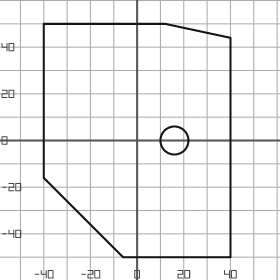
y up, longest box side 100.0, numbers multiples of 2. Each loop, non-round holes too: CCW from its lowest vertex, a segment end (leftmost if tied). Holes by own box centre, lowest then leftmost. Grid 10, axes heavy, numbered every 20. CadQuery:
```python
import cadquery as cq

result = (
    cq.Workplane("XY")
    .moveTo(-6.0, -50.0)
    .lineTo(40.0, -50.0)
    .lineTo(40.0, 44.0)
    .lineTo(12.0, 50.0)
    .lineTo(-40.0, 50.0)
    .lineTo(-40.0, -16.0)
    .close()
    .moveTo(16.0, 0.0)
    .circle(6.0)
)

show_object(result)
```